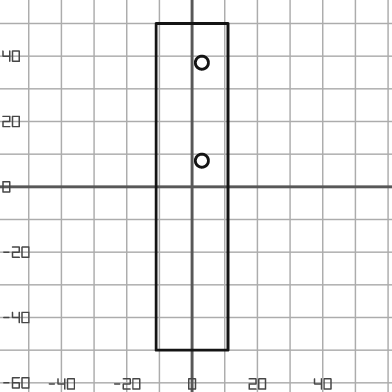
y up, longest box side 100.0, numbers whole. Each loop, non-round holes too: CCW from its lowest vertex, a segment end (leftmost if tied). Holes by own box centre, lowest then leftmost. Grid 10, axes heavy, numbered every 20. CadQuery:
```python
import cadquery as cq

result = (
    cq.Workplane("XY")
    .moveTo(-11.0, -50.0)
    .lineTo(11.0, -50.0)
    .lineTo(11.0, 50.0)
    .lineTo(-11.0, 50.0)
    .close()
    .moveTo(3.0, 8.0)
    .circle(2.0)
    .moveTo(3.0, 38.0)
    .circle(2.0)
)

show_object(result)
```